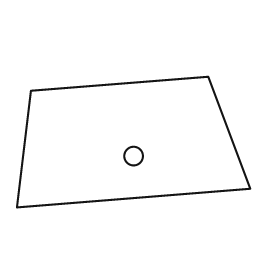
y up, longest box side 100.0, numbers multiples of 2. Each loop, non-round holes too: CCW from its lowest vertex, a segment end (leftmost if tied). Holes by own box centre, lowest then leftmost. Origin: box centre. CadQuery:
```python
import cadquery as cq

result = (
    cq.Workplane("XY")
    .moveTo(-50.0, -28.0)
    .lineTo(50.0, -20.0)
    .lineTo(32.0, 28.0)
    .lineTo(-44.0, 22.0)
    .close()
    .moveTo(0.0, -6.0)
    .circle(4.0)
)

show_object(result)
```